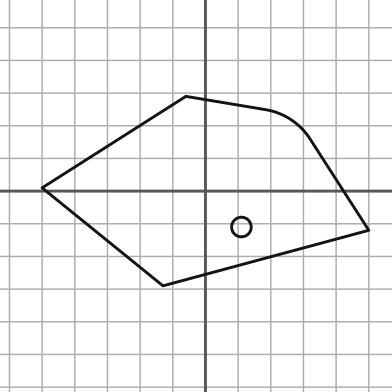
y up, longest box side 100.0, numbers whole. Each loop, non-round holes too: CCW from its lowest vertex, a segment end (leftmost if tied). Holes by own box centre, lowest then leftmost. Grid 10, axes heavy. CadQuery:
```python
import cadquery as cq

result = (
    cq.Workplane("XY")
    .moveTo(-13.0, -29.0)
    .lineTo(50.0, -12.0)
    .lineTo(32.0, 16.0)
    .threePointArc((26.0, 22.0), (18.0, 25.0))
    .lineTo(-6.0, 29.0)
    .lineTo(-50.0, 1.0)
    .close()
    .moveTo(11.0, -11.0)
    .circle(3.0)
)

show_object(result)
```